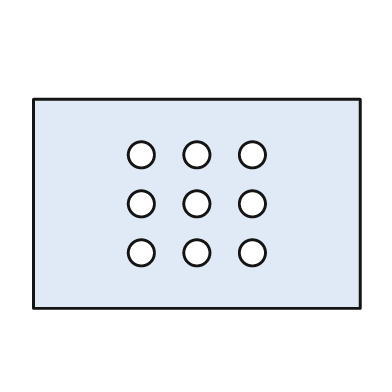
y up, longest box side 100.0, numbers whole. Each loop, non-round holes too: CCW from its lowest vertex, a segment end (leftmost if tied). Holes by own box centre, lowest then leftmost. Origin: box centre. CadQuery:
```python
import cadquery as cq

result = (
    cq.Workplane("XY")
    .moveTo(-50.0, -32.0)
    .lineTo(50.0, -32.0)
    .lineTo(50.0, 32.0)
    .lineTo(-50.0, 32.0)
    .close()
    .moveTo(-17.0, -15.0)
    .circle(4.0)
    .moveTo(0.0, -15.0)
    .circle(4.0)
    .moveTo(17.0, -15.0)
    .circle(4.0)
    .moveTo(-17.0, 0.0)
    .circle(4.0)
    .moveTo(0.0, 0.0)
    .circle(4.0)
    .moveTo(17.0, 0.0)
    .circle(4.0)
    .moveTo(-17.0, 15.0)
    .circle(4.0)
    .moveTo(0.0, 15.0)
    .circle(4.0)
    .moveTo(17.0, 15.0)
    .circle(4.0)
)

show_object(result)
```